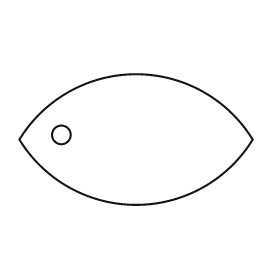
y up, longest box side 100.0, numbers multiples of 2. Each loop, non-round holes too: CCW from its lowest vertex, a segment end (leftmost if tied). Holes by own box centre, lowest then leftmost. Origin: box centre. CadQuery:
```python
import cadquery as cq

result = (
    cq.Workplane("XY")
    .moveTo(-50.0, 0.0)
    .threePointArc((0.0, -28.0), (50.0, 0.0))
    .threePointArc((0.0, 28.0), (-50.0, 0.0))
    .close()
    .moveTo(-32.0, 2.0)
    .circle(4.0)
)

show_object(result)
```